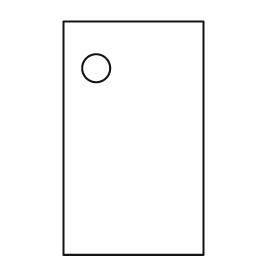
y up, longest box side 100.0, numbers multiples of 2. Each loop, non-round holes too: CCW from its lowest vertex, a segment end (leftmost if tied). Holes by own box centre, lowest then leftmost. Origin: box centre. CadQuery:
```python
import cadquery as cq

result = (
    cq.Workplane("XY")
    .moveTo(-30.0, -50.0)
    .lineTo(30.0, -50.0)
    .lineTo(30.0, 50.0)
    .lineTo(-30.0, 50.0)
    .close()
    .moveTo(-16.0, 30.0)
    .circle(6.0)
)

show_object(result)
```